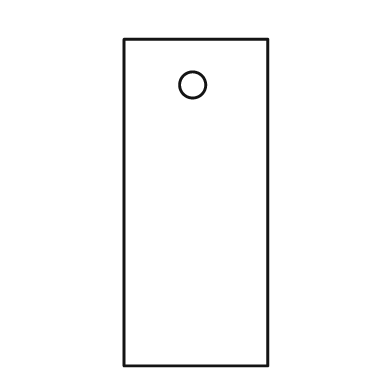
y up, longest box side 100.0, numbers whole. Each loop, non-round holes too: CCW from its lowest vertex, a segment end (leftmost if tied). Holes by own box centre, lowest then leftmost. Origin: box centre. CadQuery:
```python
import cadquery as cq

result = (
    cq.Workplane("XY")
    .moveTo(-22.0, -50.0)
    .lineTo(22.0, -50.0)
    .lineTo(22.0, 50.0)
    .lineTo(-22.0, 50.0)
    .close()
    .moveTo(-1.0, 36.0)
    .circle(4.0)
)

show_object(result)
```